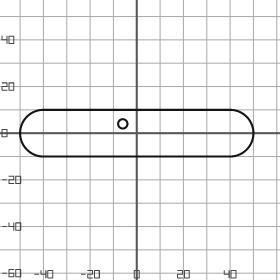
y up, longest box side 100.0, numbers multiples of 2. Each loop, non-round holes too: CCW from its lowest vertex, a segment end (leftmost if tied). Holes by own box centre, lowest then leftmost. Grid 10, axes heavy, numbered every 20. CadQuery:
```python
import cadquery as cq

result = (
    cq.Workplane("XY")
    .moveTo(-40.0, -10.0)
    .lineTo(40.0, -10.0)
    .threePointArc((50.0, 0.0), (40.0, 10.0))
    .lineTo(-40.0, 10.0)
    .threePointArc((-50.0, 0.0), (-40.0, -10.0))
    .close()
    .moveTo(-6.0, 4.0)
    .circle(2.0)
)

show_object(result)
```